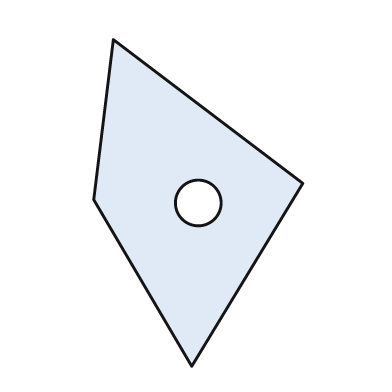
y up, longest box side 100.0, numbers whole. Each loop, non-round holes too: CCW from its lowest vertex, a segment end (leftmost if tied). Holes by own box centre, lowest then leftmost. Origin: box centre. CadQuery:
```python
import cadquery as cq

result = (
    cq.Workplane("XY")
    .moveTo(-2.0, -50.0)
    .lineTo(32.0, 6.0)
    .lineTo(-26.0, 50.0)
    .lineTo(-32.0, 1.0)
    .close()
    .moveTo(0.0, 0.0)
    .circle(7.0)
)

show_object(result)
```